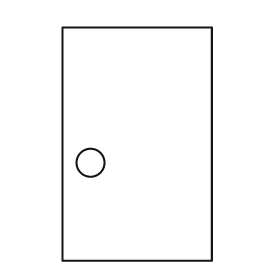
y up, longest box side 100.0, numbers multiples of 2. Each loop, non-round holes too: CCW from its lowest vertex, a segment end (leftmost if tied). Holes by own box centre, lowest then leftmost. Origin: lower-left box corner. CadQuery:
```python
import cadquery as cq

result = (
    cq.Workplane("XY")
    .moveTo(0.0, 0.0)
    .lineTo(64.0, 0.0)
    .lineTo(64.0, 100.0)
    .lineTo(0.0, 100.0)
    .close()
    .moveTo(12.0, 42.0)
    .circle(6.0)
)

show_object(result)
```